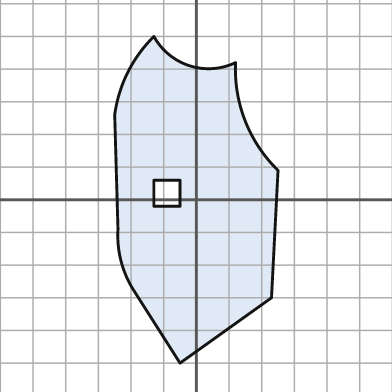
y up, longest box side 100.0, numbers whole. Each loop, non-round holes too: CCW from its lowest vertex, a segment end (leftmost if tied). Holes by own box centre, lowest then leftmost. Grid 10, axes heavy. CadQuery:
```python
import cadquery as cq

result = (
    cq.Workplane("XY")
    .moveTo(-5.0, -50.0)
    .lineTo(23.0, -30.0)
    .lineTo(25.0, 9.0)
    .threePointArc((15.0, 24.0), (12.0, 42.0))
    .threePointArc((-2.0, 41.0), (-13.0, 50.0))
    .threePointArc((-21.0, 39.0), (-25.0, 26.0))
    .lineTo(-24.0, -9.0)
    .threePointArc((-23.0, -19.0), (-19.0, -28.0))
    .close()
    .moveTo(-13.0, -2.0)
    .lineTo(-5.0, -2.0)
    .lineTo(-5.0, 6.0)
    .lineTo(-13.0, 6.0)
    .close()
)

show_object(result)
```